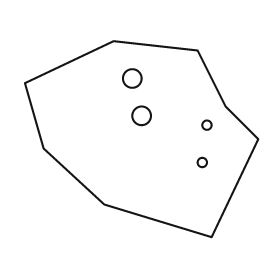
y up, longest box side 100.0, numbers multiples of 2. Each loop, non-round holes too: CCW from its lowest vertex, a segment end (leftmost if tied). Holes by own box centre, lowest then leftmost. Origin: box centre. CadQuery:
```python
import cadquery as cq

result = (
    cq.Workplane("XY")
    .moveTo(30.0, -42.0)
    .lineTo(50.0, 0.0)
    .lineTo(36.0, 14.0)
    .lineTo(24.0, 38.0)
    .lineTo(-12.0, 42.0)
    .lineTo(-50.0, 24.0)
    .lineTo(-42.0, -4.0)
    .lineTo(-16.0, -28.0)
    .close()
    .moveTo(26.0, -10.0)
    .circle(2.0)
    .moveTo(28.0, 6.0)
    .circle(2.0)
    .moveTo(0.0, 10.0)
    .circle(4.0)
    .moveTo(-4.0, 26.0)
    .circle(4.0)
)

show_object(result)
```